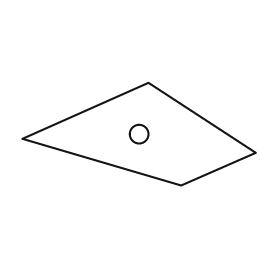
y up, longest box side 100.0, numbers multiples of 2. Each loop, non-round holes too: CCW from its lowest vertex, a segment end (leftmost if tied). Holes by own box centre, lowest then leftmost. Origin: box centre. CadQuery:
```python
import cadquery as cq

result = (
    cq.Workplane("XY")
    .moveTo(18.0, -22.0)
    .lineTo(50.0, -8.0)
    .lineTo(4.0, 22.0)
    .lineTo(-50.0, -2.0)
    .close()
    .moveTo(0.0, 0.0)
    .circle(4.0)
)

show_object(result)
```